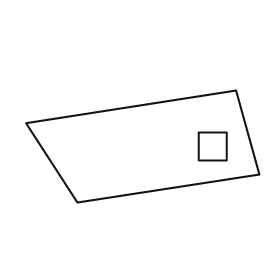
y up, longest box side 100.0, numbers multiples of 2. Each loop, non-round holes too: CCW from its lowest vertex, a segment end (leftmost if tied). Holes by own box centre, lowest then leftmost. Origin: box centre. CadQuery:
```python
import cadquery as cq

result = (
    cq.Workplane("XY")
    .moveTo(-28.0, -24.0)
    .lineTo(50.0, -12.0)
    .lineTo(40.0, 24.0)
    .lineTo(-50.0, 10.0)
    .close()
    .moveTo(24.0, -6.0)
    .lineTo(36.0, -6.0)
    .lineTo(36.0, 6.0)
    .lineTo(24.0, 6.0)
    .close()
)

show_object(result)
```